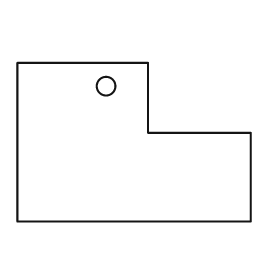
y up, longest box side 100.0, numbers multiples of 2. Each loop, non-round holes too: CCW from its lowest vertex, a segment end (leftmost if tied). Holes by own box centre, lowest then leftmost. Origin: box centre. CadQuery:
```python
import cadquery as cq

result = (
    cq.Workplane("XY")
    .moveTo(-50.0, -34.0)
    .lineTo(50.0, -34.0)
    .lineTo(50.0, 4.0)
    .lineTo(6.0, 4.0)
    .lineTo(6.0, 34.0)
    .lineTo(-50.0, 34.0)
    .close()
    .moveTo(-12.0, 24.0)
    .circle(4.0)
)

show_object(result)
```